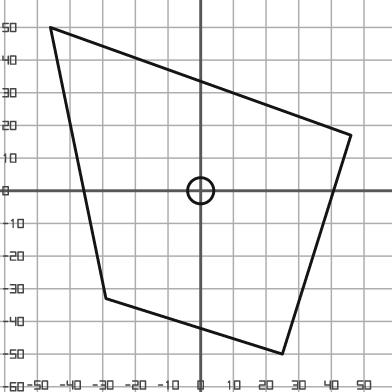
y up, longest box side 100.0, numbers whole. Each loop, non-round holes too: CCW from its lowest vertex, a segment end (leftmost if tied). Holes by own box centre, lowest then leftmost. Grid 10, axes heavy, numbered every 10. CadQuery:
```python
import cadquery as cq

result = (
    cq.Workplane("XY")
    .moveTo(25.0, -50.0)
    .lineTo(46.0, 17.0)
    .lineTo(-46.0, 50.0)
    .lineTo(-29.0, -33.0)
    .close()
    .moveTo(0.0, 0.0)
    .circle(4.0)
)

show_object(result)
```